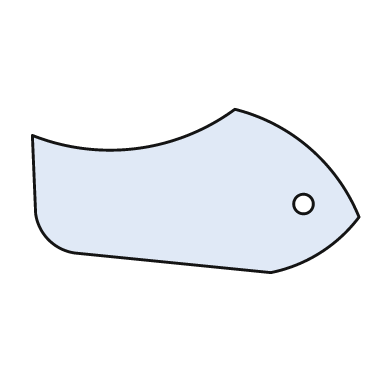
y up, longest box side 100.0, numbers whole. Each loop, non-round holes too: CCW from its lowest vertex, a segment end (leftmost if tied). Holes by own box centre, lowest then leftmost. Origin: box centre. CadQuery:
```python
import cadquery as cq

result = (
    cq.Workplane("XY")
    .moveTo(23.0, -25.0)
    .threePointArc((38.0, -19.0), (50.0, -8.0))
    .threePointArc((35.0, 13.0), (12.0, 25.0))
    .threePointArc((-18.0, 13.0), (-50.0, 17.0))
    .lineTo(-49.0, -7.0)
    .threePointArc((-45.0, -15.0), (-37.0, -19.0))
    .close()
    .moveTo(33.0, -4.0)
    .circle(3.0)
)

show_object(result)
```